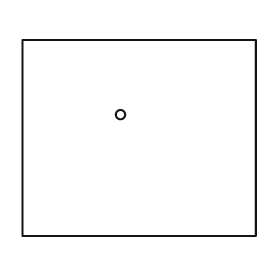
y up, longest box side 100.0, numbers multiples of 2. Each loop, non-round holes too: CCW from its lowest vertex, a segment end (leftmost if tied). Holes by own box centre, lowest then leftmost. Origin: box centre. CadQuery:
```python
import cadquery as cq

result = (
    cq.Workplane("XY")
    .moveTo(-50.0, -42.0)
    .lineTo(50.0, -42.0)
    .lineTo(50.0, 42.0)
    .lineTo(-50.0, 42.0)
    .close()
    .moveTo(-8.0, 10.0)
    .circle(2.0)
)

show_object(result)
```